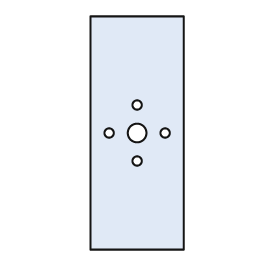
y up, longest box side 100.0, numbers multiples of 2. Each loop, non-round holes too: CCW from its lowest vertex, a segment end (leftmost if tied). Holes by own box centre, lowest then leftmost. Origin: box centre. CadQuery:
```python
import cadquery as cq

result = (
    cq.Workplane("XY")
    .moveTo(-20.0, -50.0)
    .lineTo(20.0, -50.0)
    .lineTo(20.0, 50.0)
    .lineTo(-20.0, 50.0)
    .close()
    .moveTo(0.0, -12.0)
    .circle(2.0)
    .moveTo(-12.0, 0.0)
    .circle(2.0)
    .moveTo(0.0, 0.0)
    .circle(4.0)
    .moveTo(12.0, 0.0)
    .circle(2.0)
    .moveTo(0.0, 12.0)
    .circle(2.0)
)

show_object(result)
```